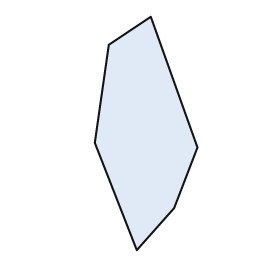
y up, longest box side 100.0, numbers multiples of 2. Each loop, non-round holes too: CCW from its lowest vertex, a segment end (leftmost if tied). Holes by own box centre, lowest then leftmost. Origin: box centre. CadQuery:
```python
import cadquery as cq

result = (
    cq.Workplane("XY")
    .moveTo(-4.0, -50.0)
    .lineTo(12.0, -32.0)
    .lineTo(22.0, -6.0)
    .lineTo(2.0, 50.0)
    .lineTo(-16.0, 38.0)
    .lineTo(-22.0, -4.0)
    .close()
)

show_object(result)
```